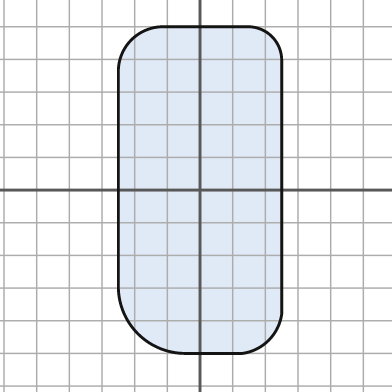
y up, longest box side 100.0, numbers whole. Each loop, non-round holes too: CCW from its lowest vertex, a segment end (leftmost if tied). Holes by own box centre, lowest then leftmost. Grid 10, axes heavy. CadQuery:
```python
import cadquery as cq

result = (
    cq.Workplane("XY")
    .moveTo(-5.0, -50.0)
    .lineTo(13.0, -50.0)
    .threePointArc((21.0, -46.0), (25.0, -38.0))
    .lineTo(25.0, 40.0)
    .threePointArc((22.0, 47.0), (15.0, 50.0))
    .lineTo(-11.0, 50.0)
    .threePointArc((-21.0, 46.0), (-25.0, 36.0))
    .lineTo(-25.0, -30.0)
    .threePointArc((-19.0, -44.0), (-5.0, -50.0))
    .close()
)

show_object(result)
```